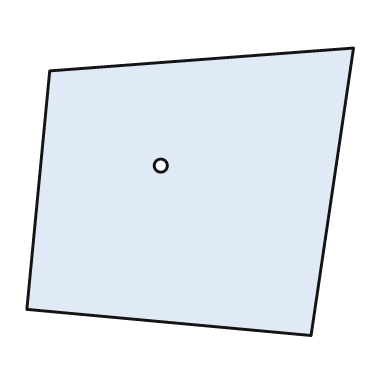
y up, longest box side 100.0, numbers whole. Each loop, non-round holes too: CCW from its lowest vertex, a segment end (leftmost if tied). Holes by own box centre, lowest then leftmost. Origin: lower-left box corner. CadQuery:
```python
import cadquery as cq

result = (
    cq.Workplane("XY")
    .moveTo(87.0, 0.0)
    .lineTo(100.0, 88.0)
    .lineTo(7.0, 81.0)
    .lineTo(0.0, 8.0)
    .close()
    .moveTo(41.0, 52.0)
    .circle(2.0)
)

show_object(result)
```